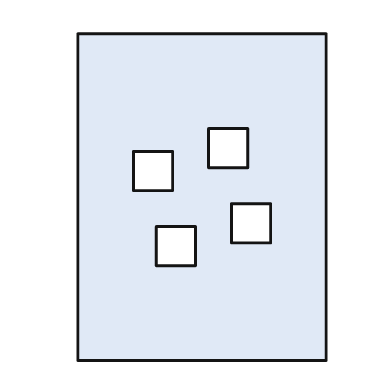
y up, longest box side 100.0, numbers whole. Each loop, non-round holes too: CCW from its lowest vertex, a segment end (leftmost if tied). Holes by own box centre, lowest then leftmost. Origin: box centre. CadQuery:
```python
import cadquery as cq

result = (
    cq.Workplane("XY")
    .moveTo(-38.0, -50.0)
    .lineTo(38.0, -50.0)
    .lineTo(38.0, 50.0)
    .lineTo(-38.0, 50.0)
    .close()
    .moveTo(-14.0, -21.0)
    .lineTo(-2.0, -21.0)
    .lineTo(-2.0, -9.0)
    .lineTo(-14.0, -9.0)
    .close()
    .moveTo(9.0, -14.0)
    .lineTo(21.0, -14.0)
    .lineTo(21.0, -2.0)
    .lineTo(9.0, -2.0)
    .close()
    .moveTo(-21.0, 2.0)
    .lineTo(-9.0, 2.0)
    .lineTo(-9.0, 14.0)
    .lineTo(-21.0, 14.0)
    .close()
    .moveTo(2.0, 9.0)
    .lineTo(14.0, 9.0)
    .lineTo(14.0, 21.0)
    .lineTo(2.0, 21.0)
    .close()
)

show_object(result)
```